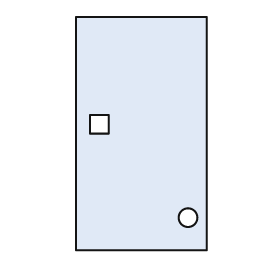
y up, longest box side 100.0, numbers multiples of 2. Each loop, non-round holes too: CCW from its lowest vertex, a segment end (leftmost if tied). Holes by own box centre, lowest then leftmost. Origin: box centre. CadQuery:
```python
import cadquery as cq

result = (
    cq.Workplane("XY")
    .moveTo(-28.0, -50.0)
    .lineTo(28.0, -50.0)
    .lineTo(28.0, 50.0)
    .lineTo(-28.0, 50.0)
    .close()
    .moveTo(20.0, -36.0)
    .circle(4.0)
    .moveTo(-22.0, 0.0)
    .lineTo(-14.0, 0.0)
    .lineTo(-14.0, 8.0)
    .lineTo(-22.0, 8.0)
    .close()
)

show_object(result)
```